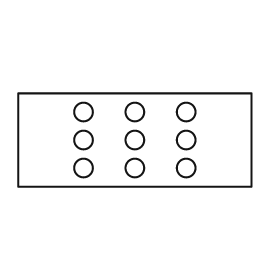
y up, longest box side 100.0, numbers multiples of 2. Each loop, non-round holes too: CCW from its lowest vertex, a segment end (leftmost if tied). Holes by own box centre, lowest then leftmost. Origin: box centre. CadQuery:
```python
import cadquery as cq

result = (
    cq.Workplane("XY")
    .moveTo(-50.0, -20.0)
    .lineTo(50.0, -20.0)
    .lineTo(50.0, 20.0)
    .lineTo(-50.0, 20.0)
    .close()
    .moveTo(-22.0, -12.0)
    .circle(4.0)
    .moveTo(0.0, -12.0)
    .circle(4.0)
    .moveTo(22.0, -12.0)
    .circle(4.0)
    .moveTo(-22.0, 0.0)
    .circle(4.0)
    .moveTo(0.0, 0.0)
    .circle(4.0)
    .moveTo(22.0, 0.0)
    .circle(4.0)
    .moveTo(-22.0, 12.0)
    .circle(4.0)
    .moveTo(0.0, 12.0)
    .circle(4.0)
    .moveTo(22.0, 12.0)
    .circle(4.0)
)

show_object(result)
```